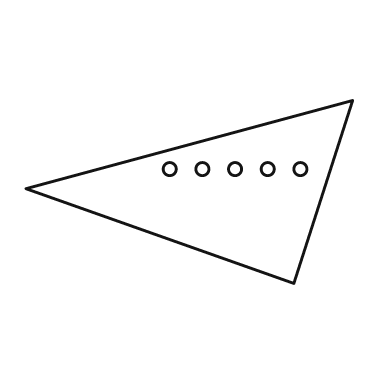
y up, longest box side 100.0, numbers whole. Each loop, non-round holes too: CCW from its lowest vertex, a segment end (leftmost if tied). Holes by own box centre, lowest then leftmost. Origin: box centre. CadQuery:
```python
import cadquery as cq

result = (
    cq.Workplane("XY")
    .moveTo(32.0, -28.0)
    .lineTo(50.0, 28.0)
    .lineTo(-50.0, 1.0)
    .close()
    .moveTo(-6.0, 7.0)
    .circle(2.0)
    .moveTo(4.0, 7.0)
    .circle(2.0)
    .moveTo(14.0, 7.0)
    .circle(2.0)
    .moveTo(24.0, 7.0)
    .circle(2.0)
    .moveTo(34.0, 7.0)
    .circle(2.0)
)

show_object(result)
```